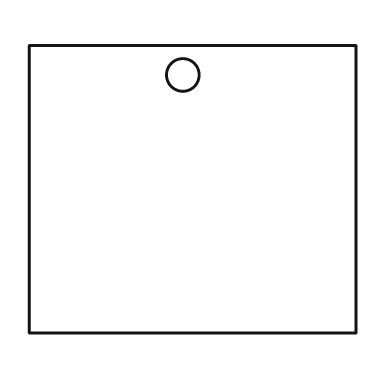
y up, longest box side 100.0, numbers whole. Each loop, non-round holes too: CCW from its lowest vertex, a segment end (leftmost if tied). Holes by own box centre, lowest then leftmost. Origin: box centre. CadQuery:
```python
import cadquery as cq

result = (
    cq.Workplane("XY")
    .moveTo(-50.0, -44.0)
    .lineTo(50.0, -44.0)
    .lineTo(50.0, 44.0)
    .lineTo(-50.0, 44.0)
    .close()
    .moveTo(-3.0, 35.0)
    .circle(5.0)
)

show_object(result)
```